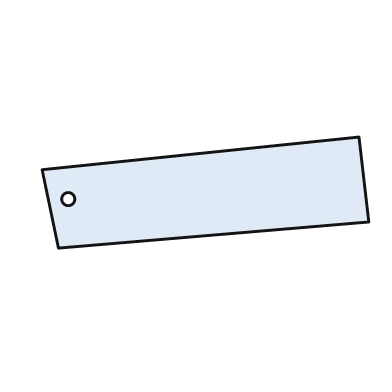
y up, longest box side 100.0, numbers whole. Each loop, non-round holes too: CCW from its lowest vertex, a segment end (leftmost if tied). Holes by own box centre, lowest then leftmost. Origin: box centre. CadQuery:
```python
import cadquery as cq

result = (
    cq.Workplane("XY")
    .moveTo(-45.0, -17.0)
    .lineTo(50.0, -9.0)
    .lineTo(47.0, 17.0)
    .lineTo(-50.0, 7.0)
    .close()
    .moveTo(-42.0, -2.0)
    .circle(2.0)
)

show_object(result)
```